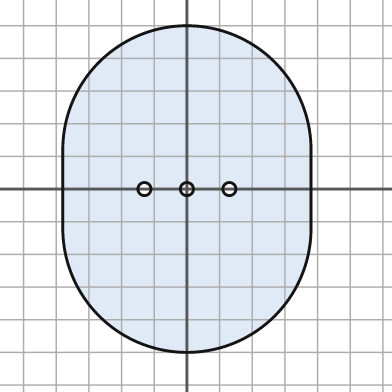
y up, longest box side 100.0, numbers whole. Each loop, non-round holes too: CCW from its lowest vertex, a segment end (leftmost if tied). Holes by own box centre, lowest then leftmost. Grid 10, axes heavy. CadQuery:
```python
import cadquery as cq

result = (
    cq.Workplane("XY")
    .moveTo(-38.0, -12.0)
    .threePointArc((0.0, -50.0), (38.0, -12.0))
    .lineTo(38.0, 12.0)
    .threePointArc((0.0, 50.0), (-38.0, 12.0))
    .close()
    .moveTo(-13.0, 0.0)
    .circle(2.0)
    .moveTo(0.0, 0.0)
    .circle(2.0)
    .moveTo(13.0, 0.0)
    .circle(2.0)
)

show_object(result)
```